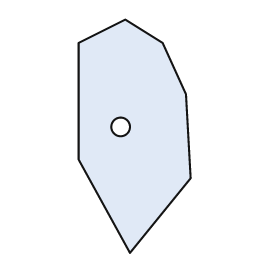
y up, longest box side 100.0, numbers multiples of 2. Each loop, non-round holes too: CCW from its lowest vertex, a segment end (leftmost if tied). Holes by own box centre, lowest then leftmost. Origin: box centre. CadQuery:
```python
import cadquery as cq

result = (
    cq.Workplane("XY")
    .moveTo(-2.0, -50.0)
    .lineTo(24.0, -18.0)
    .lineTo(22.0, 18.0)
    .lineTo(12.0, 40.0)
    .lineTo(-4.0, 50.0)
    .lineTo(-24.0, 40.0)
    .lineTo(-24.0, -10.0)
    .close()
    .moveTo(-6.0, 4.0)
    .circle(4.0)
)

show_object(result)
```